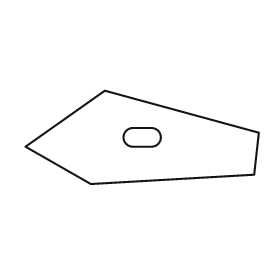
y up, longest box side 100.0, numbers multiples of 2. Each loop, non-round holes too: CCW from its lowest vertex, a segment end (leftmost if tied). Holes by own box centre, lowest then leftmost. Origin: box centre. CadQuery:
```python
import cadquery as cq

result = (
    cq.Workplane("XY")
    .moveTo(-22.0, -20.0)
    .lineTo(48.0, -16.0)
    .lineTo(50.0, 2.0)
    .lineTo(-16.0, 20.0)
    .lineTo(-50.0, -4.0)
    .close()
    .moveTo(-4.0, -4.0)
    .lineTo(4.0, -4.0)
    .threePointArc((8.0, 0.0), (4.0, 4.0))
    .lineTo(-4.0, 4.0)
    .threePointArc((-8.0, 0.0), (-4.0, -4.0))
    .close()
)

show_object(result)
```